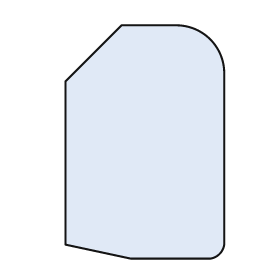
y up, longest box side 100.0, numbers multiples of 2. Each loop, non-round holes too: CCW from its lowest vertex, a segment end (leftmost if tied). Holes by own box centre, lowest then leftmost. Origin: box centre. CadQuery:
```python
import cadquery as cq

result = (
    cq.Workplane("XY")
    .moveTo(-6.0, -50.0)
    .lineTo(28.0, -50.0)
    .threePointArc((32.0, -48.0), (34.0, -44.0))
    .lineTo(34.0, 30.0)
    .threePointArc((28.0, 44.0), (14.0, 50.0))
    .lineTo(-10.0, 50.0)
    .lineTo(-34.0, 26.0)
    .lineTo(-34.0, -44.0)
    .close()
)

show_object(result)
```